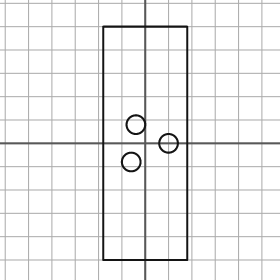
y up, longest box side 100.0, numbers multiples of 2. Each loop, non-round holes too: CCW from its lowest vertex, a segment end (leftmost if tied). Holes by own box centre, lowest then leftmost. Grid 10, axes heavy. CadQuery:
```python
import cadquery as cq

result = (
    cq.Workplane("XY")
    .moveTo(-18.0, -50.0)
    .lineTo(18.0, -50.0)
    .lineTo(18.0, 50.0)
    .lineTo(-18.0, 50.0)
    .close()
    .moveTo(-6.0, -8.0)
    .circle(4.0)
    .moveTo(10.0, 0.0)
    .circle(4.0)
    .moveTo(-4.0, 8.0)
    .circle(4.0)
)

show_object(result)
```